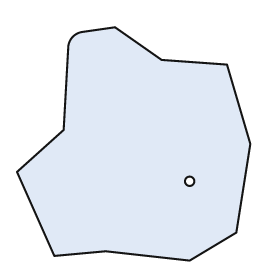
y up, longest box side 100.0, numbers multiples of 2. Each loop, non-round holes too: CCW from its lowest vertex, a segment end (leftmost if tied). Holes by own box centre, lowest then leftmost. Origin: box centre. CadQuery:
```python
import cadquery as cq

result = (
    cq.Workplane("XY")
    .moveTo(24.0, -50.0)
    .lineTo(44.0, -38.0)
    .lineTo(50.0, 0.0)
    .lineTo(40.0, 34.0)
    .lineTo(12.0, 36.0)
    .lineTo(-8.0, 50.0)
    .lineTo(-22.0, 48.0)
    .threePointArc((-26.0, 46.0), (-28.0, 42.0))
    .lineTo(-30.0, 6.0)
    .lineTo(-50.0, -12.0)
    .lineTo(-34.0, -48.0)
    .lineTo(-12.0, -46.0)
    .close()
    .moveTo(24.0, -16.0)
    .circle(2.0)
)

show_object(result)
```